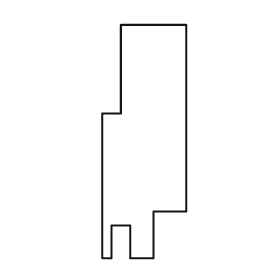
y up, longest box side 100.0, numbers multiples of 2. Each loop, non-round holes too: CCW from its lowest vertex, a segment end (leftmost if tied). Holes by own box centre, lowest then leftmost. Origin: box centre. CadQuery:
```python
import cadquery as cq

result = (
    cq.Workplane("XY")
    .moveTo(-18.0, -50.0)
    .lineTo(-14.0, -50.0)
    .lineTo(-14.0, -36.0)
    .lineTo(-6.0, -36.0)
    .lineTo(-6.0, -50.0)
    .lineTo(4.0, -50.0)
    .lineTo(4.0, -30.0)
    .lineTo(18.0, -30.0)
    .lineTo(18.0, 50.0)
    .lineTo(-10.0, 50.0)
    .lineTo(-10.0, 12.0)
    .lineTo(-18.0, 12.0)
    .close()
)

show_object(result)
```